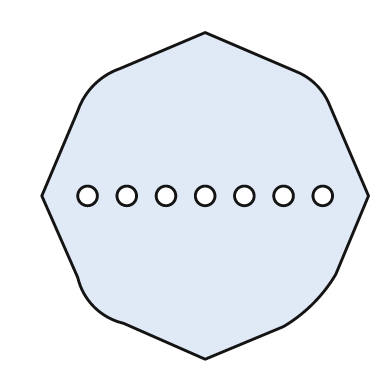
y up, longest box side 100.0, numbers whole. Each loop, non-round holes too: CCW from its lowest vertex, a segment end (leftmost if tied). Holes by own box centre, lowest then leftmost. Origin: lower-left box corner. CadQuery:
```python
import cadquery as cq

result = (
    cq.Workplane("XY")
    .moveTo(50.0, 0.0)
    .lineTo(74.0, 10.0)
    .threePointArc((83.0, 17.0), (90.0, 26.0))
    .lineTo(100.0, 50.0)
    .lineTo(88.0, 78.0)
    .threePointArc((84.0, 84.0), (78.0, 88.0))
    .lineTo(50.0, 100.0)
    .lineTo(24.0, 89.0)
    .threePointArc((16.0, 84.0), (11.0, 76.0))
    .lineTo(0.0, 50.0)
    .lineTo(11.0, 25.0)
    .threePointArc((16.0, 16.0), (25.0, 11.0))
    .close()
    .moveTo(14.0, 50.0)
    .circle(3.0)
    .moveTo(26.0, 50.0)
    .circle(3.0)
    .moveTo(38.0, 50.0)
    .circle(3.0)
    .moveTo(50.0, 50.0)
    .circle(3.0)
    .moveTo(62.0, 50.0)
    .circle(3.0)
    .moveTo(74.0, 50.0)
    .circle(3.0)
    .moveTo(86.0, 50.0)
    .circle(3.0)
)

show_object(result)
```